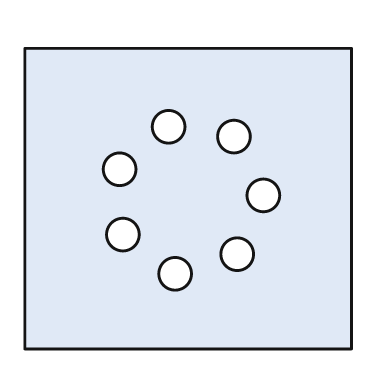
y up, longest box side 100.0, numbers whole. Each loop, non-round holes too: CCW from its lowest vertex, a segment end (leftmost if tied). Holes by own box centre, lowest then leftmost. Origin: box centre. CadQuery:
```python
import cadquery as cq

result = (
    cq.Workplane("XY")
    .moveTo(-50.0, -46.0)
    .lineTo(50.0, -46.0)
    .lineTo(50.0, 46.0)
    .lineTo(-50.0, 46.0)
    .close()
    .moveTo(-4.0, -23.0)
    .circle(5.0)
    .moveTo(15.0, -17.0)
    .circle(5.0)
    .moveTo(-20.0, -11.0)
    .circle(5.0)
    .moveTo(23.0, 1.0)
    .circle(5.0)
    .moveTo(-21.0, 9.0)
    .circle(5.0)
    .moveTo(14.0, 19.0)
    .circle(5.0)
    .moveTo(-6.0, 22.0)
    .circle(5.0)
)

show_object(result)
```